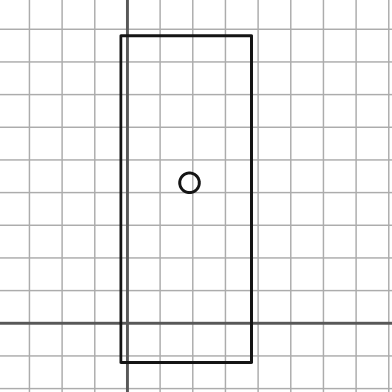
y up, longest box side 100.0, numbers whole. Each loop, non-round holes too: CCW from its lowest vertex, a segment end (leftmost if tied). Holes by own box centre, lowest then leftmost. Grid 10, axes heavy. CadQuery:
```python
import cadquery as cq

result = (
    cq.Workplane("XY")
    .moveTo(-2.0, -12.0)
    .lineTo(38.0, -12.0)
    .lineTo(38.0, 88.0)
    .lineTo(-2.0, 88.0)
    .close()
    .moveTo(19.0, 43.0)
    .circle(3.0)
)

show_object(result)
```